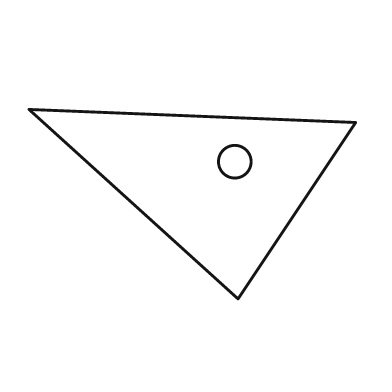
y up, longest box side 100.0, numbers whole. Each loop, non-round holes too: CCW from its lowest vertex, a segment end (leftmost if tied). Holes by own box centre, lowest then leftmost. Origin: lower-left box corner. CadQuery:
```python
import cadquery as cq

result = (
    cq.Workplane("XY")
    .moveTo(64.0, 0.0)
    .lineTo(100.0, 54.0)
    .lineTo(0.0, 58.0)
    .close()
    .moveTo(63.0, 42.0)
    .circle(5.0)
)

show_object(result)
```